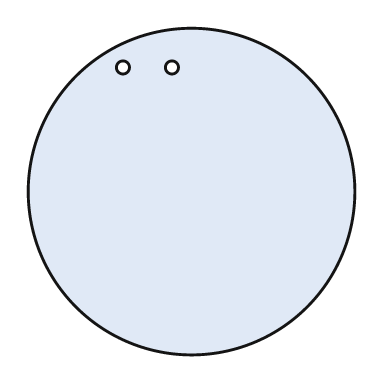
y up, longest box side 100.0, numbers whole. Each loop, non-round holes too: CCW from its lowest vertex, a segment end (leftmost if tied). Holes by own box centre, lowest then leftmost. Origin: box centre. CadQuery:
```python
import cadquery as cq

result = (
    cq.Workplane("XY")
    .moveTo(0.0, 0.0)
    .circle(50.0)
    .moveTo(-21.0, 38.0)
    .circle(2.0)
    .moveTo(-6.0, 38.0)
    .circle(2.0)
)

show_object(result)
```